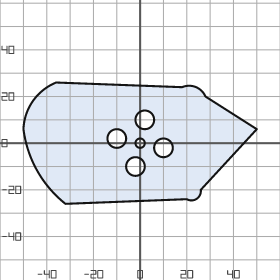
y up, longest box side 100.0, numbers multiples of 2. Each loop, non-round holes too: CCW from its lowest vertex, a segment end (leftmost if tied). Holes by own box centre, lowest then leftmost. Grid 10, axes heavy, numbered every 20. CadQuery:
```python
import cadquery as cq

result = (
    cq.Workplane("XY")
    .moveTo(-32.0, -26.0)
    .lineTo(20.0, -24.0)
    .threePointArc((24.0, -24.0), (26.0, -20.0))
    .lineTo(50.0, 6.0)
    .lineTo(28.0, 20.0)
    .threePointArc((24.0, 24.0), (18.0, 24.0))
    .lineTo(-36.0, 26.0)
    .threePointArc((-46.0, 18.0), (-50.0, 6.0))
    .threePointArc((-44.0, -12.0), (-32.0, -26.0))
    .close()
    .moveTo(-2.0, -10.0)
    .circle(4.0)
    .moveTo(10.0, -2.0)
    .circle(4.0)
    .moveTo(0.0, 0.0)
    .circle(2.0)
    .moveTo(-10.0, 2.0)
    .circle(4.0)
    .moveTo(2.0, 10.0)
    .circle(4.0)
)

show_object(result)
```